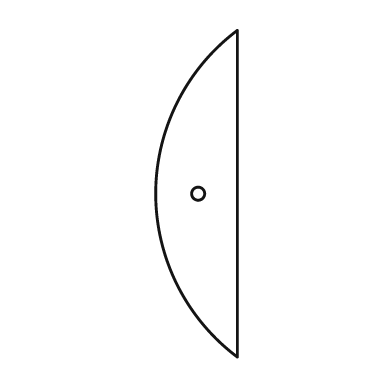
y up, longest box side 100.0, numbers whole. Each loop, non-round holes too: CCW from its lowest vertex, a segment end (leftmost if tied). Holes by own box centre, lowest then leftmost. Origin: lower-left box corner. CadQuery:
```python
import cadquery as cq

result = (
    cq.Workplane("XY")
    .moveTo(25.0, 0.0)
    .lineTo(25.0, 100.0)
    .threePointArc((0.0, 50.0), (25.0, 0.0))
    .close()
    .moveTo(13.0, 50.0)
    .circle(2.0)
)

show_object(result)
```